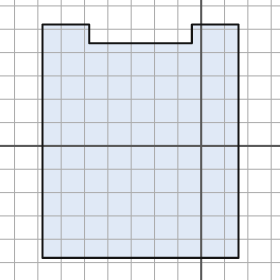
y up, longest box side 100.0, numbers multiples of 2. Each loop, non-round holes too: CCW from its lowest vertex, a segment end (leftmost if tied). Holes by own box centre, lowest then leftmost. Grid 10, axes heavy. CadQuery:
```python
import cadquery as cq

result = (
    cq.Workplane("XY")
    .moveTo(-68.0, -48.0)
    .lineTo(16.0, -48.0)
    .lineTo(16.0, 52.0)
    .lineTo(-4.0, 52.0)
    .lineTo(-4.0, 44.0)
    .lineTo(-48.0, 44.0)
    .lineTo(-48.0, 52.0)
    .lineTo(-68.0, 52.0)
    .close()
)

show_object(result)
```